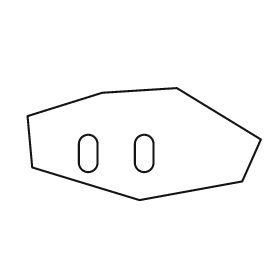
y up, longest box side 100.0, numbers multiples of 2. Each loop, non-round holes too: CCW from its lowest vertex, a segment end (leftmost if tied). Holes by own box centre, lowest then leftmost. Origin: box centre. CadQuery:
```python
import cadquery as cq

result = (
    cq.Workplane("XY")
    .moveTo(-2.0, -24.0)
    .lineTo(42.0, -16.0)
    .lineTo(50.0, 2.0)
    .lineTo(14.0, 24.0)
    .lineTo(-18.0, 22.0)
    .lineTo(-50.0, 12.0)
    .lineTo(-48.0, -10.0)
    .close()
    .moveTo(-28.0, -8.0)
    .threePointArc((-24.0, -12.0), (-20.0, -8.0))
    .lineTo(-20.0, 0.0)
    .threePointArc((-24.0, 4.0), (-28.0, 0.0))
    .close()
    .moveTo(-4.0, -8.0)
    .threePointArc((0.0, -12.0), (4.0, -8.0))
    .lineTo(4.0, 0.0)
    .threePointArc((0.0, 4.0), (-4.0, 0.0))
    .close()
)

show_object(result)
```